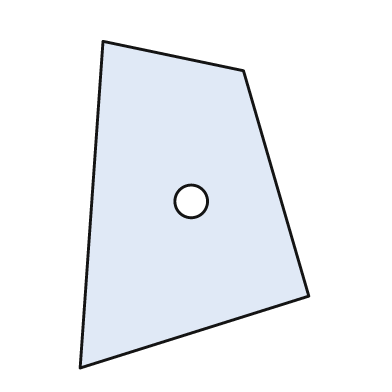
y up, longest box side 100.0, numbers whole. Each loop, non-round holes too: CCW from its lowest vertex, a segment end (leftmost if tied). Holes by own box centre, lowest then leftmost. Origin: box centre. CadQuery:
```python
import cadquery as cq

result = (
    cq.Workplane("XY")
    .moveTo(-35.0, -50.0)
    .lineTo(35.0, -28.0)
    .lineTo(15.0, 41.0)
    .lineTo(-28.0, 50.0)
    .close()
    .moveTo(-1.0, 1.0)
    .circle(5.0)
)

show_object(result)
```